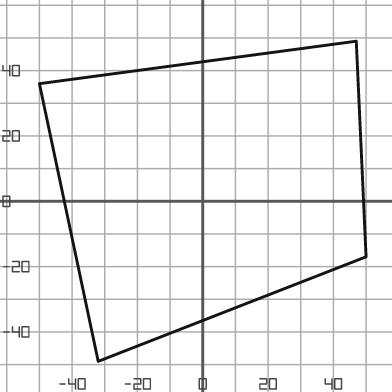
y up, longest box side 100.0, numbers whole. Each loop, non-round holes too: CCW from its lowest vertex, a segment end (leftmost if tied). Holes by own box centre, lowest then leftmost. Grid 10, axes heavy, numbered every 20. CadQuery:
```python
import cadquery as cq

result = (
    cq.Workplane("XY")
    .moveTo(-32.0, -49.0)
    .lineTo(50.0, -17.0)
    .lineTo(47.0, 49.0)
    .lineTo(-50.0, 36.0)
    .close()
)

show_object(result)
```